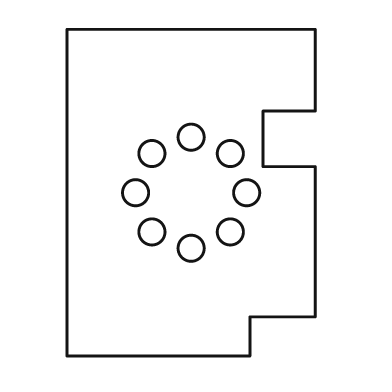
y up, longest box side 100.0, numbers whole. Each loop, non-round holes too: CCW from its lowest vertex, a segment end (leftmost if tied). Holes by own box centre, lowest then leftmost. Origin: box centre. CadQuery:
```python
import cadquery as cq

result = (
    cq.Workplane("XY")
    .moveTo(-38.0, -50.0)
    .lineTo(18.0, -50.0)
    .lineTo(18.0, -38.0)
    .lineTo(38.0, -38.0)
    .lineTo(38.0, 8.0)
    .lineTo(22.0, 8.0)
    .lineTo(22.0, 25.0)
    .lineTo(38.0, 25.0)
    .lineTo(38.0, 50.0)
    .lineTo(-38.0, 50.0)
    .close()
    .moveTo(0.0, -17.0)
    .circle(4.0)
    .moveTo(-12.0, -12.0)
    .circle(4.0)
    .moveTo(12.0, -12.0)
    .circle(4.0)
    .moveTo(-17.0, 0.0)
    .circle(4.0)
    .moveTo(17.0, 0.0)
    .circle(4.0)
    .moveTo(-12.0, 12.0)
    .circle(4.0)
    .moveTo(12.0, 12.0)
    .circle(4.0)
    .moveTo(0.0, 17.0)
    .circle(4.0)
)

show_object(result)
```